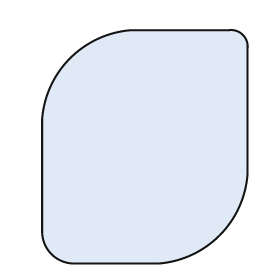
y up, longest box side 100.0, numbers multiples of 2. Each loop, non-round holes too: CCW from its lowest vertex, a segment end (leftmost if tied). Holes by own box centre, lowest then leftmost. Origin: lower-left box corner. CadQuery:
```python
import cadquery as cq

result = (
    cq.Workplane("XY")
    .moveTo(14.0, 0.0)
    .lineTo(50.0, 0.0)
    .threePointArc((76.0, 12.0), (88.0, 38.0))
    .lineTo(88.0, 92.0)
    .threePointArc((86.0, 98.0), (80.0, 100.0))
    .lineTo(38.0, 100.0)
    .threePointArc((12.0, 88.0), (0.0, 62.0))
    .lineTo(0.0, 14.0)
    .threePointArc((4.0, 4.0), (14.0, 0.0))
    .close()
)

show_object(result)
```